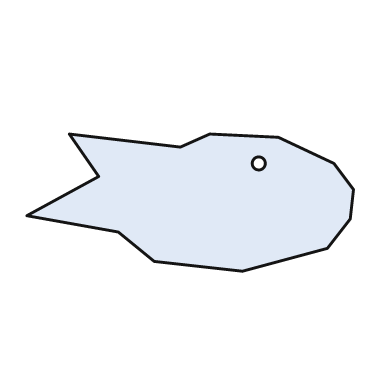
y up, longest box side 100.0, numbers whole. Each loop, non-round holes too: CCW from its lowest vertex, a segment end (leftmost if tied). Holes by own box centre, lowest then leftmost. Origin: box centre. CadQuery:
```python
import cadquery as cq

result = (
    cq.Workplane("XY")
    .moveTo(16.0, -21.0)
    .lineTo(42.0, -14.0)
    .lineTo(49.0, -5.0)
    .lineTo(50.0, 4.0)
    .lineTo(44.0, 12.0)
    .lineTo(27.0, 20.0)
    .lineTo(6.0, 21.0)
    .lineTo(-3.0, 17.0)
    .lineTo(-37.0, 21.0)
    .lineTo(-28.0, 8.0)
    .lineTo(-50.0, -4.0)
    .lineTo(-22.0, -9.0)
    .lineTo(-11.0, -18.0)
    .close()
    .moveTo(21.0, 12.0)
    .circle(2.0)
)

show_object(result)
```